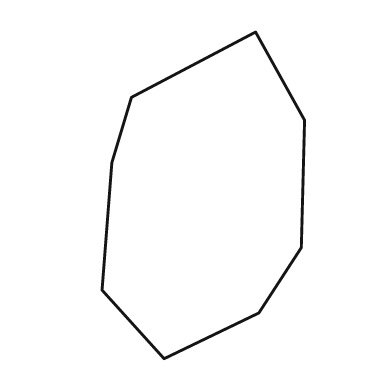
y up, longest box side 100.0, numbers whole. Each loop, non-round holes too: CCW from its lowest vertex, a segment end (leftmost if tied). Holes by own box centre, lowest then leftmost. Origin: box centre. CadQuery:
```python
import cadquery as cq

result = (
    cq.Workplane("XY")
    .moveTo(-12.0, -50.0)
    .lineTo(17.0, -36.0)
    .lineTo(30.0, -16.0)
    .lineTo(31.0, 23.0)
    .lineTo(16.0, 50.0)
    .lineTo(-22.0, 30.0)
    .lineTo(-28.0, 10.0)
    .lineTo(-31.0, -29.0)
    .close()
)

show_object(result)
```